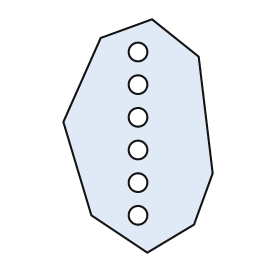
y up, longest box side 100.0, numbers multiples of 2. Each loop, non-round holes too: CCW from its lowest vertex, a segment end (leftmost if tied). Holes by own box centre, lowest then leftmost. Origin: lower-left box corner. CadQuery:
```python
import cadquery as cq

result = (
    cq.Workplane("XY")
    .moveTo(36.0, 0.0)
    .lineTo(56.0, 12.0)
    .lineTo(64.0, 34.0)
    .lineTo(58.0, 84.0)
    .lineTo(38.0, 100.0)
    .lineTo(16.0, 92.0)
    .lineTo(0.0, 56.0)
    .lineTo(12.0, 16.0)
    .close()
    .moveTo(32.0, 16.0)
    .circle(4.0)
    .moveTo(32.0, 30.0)
    .circle(4.0)
    .moveTo(32.0, 44.0)
    .circle(4.0)
    .moveTo(32.0, 58.0)
    .circle(4.0)
    .moveTo(32.0, 72.0)
    .circle(4.0)
    .moveTo(32.0, 86.0)
    .circle(4.0)
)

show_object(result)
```